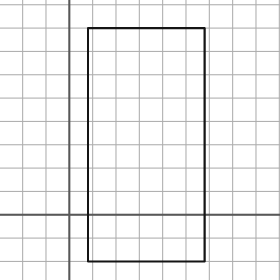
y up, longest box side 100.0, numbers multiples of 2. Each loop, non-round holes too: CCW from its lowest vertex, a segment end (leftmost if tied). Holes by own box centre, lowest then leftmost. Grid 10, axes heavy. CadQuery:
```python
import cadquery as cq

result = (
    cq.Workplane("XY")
    .moveTo(8.0, -20.0)
    .lineTo(58.0, -20.0)
    .lineTo(58.0, 80.0)
    .lineTo(8.0, 80.0)
    .close()
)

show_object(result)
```